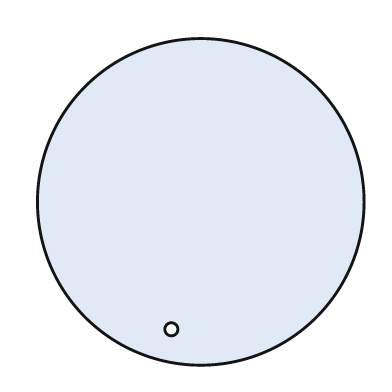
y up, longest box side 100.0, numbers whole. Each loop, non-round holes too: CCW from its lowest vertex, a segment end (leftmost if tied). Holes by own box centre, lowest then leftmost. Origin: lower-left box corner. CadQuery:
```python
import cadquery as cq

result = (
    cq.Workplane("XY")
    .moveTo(50.0, 50.0)
    .circle(50.0)
    .moveTo(41.0, 11.0)
    .circle(2.0)
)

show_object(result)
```